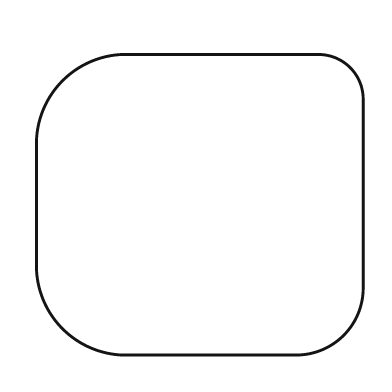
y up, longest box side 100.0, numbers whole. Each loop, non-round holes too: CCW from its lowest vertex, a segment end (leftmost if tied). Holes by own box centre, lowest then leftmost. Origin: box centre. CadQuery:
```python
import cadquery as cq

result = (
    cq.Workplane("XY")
    .moveTo(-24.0, -46.0)
    .lineTo(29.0, -46.0)
    .threePointArc((44.0, -40.0), (50.0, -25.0))
    .lineTo(50.0, 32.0)
    .threePointArc((46.0, 42.0), (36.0, 46.0))
    .lineTo(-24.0, 46.0)
    .threePointArc((-42.0, 38.0), (-50.0, 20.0))
    .lineTo(-50.0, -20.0)
    .threePointArc((-42.0, -38.0), (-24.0, -46.0))
    .close()
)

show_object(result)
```